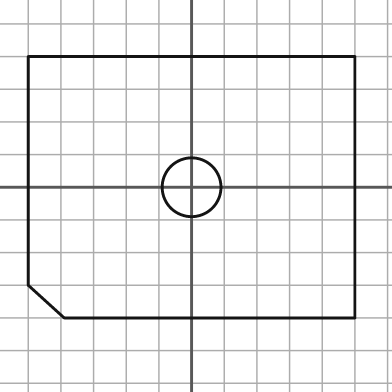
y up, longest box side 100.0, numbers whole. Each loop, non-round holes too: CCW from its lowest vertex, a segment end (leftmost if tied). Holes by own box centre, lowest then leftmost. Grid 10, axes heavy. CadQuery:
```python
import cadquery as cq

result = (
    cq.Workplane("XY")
    .moveTo(-39.0, -40.0)
    .lineTo(50.0, -40.0)
    .lineTo(50.0, 40.0)
    .lineTo(-50.0, 40.0)
    .lineTo(-50.0, -30.0)
    .close()
    .moveTo(0.0, 0.0)
    .circle(9.0)
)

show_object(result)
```